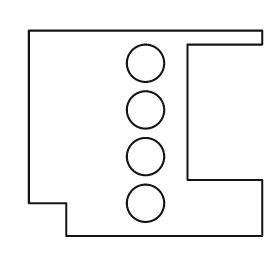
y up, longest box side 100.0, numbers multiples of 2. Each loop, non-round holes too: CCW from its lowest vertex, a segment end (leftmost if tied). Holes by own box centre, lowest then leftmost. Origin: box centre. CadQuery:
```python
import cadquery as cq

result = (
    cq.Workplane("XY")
    .moveTo(-34.0, -44.0)
    .lineTo(50.0, -44.0)
    .lineTo(50.0, -20.0)
    .lineTo(18.0, -20.0)
    .lineTo(18.0, 38.0)
    .lineTo(50.0, 38.0)
    .lineTo(50.0, 44.0)
    .lineTo(-50.0, 44.0)
    .lineTo(-50.0, -30.0)
    .lineTo(-34.0, -30.0)
    .close()
    .moveTo(0.0, -30.0)
    .circle(8.0)
    .moveTo(0.0, -10.0)
    .circle(8.0)
    .moveTo(0.0, 10.0)
    .circle(8.0)
    .moveTo(0.0, 30.0)
    .circle(8.0)
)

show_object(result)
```